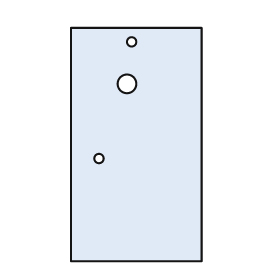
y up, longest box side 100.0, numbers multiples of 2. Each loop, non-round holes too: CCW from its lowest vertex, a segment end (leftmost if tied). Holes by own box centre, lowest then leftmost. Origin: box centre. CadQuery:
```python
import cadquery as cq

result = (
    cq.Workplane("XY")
    .moveTo(-28.0, -50.0)
    .lineTo(28.0, -50.0)
    .lineTo(28.0, 50.0)
    .lineTo(-28.0, 50.0)
    .close()
    .moveTo(-16.0, -6.0)
    .circle(2.0)
    .moveTo(-4.0, 26.0)
    .circle(4.0)
    .moveTo(-2.0, 44.0)
    .circle(2.0)
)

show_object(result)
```